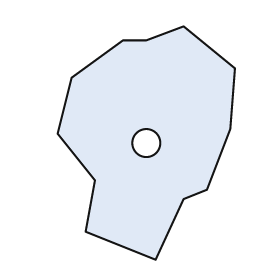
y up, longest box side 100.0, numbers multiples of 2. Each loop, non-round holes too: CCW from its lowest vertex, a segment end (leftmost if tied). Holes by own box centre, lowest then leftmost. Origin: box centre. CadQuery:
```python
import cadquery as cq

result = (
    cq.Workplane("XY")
    .moveTo(4.0, -50.0)
    .lineTo(16.0, -24.0)
    .lineTo(26.0, -20.0)
    .lineTo(36.0, 6.0)
    .lineTo(38.0, 32.0)
    .lineTo(16.0, 50.0)
    .lineTo(0.0, 44.0)
    .lineTo(-10.0, 44.0)
    .lineTo(-32.0, 28.0)
    .lineTo(-38.0, 4.0)
    .lineTo(-22.0, -16.0)
    .lineTo(-26.0, -38.0)
    .close()
    .moveTo(0.0, 0.0)
    .circle(6.0)
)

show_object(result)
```